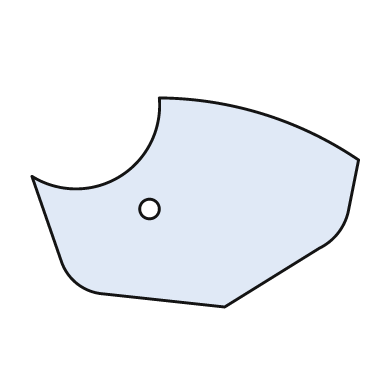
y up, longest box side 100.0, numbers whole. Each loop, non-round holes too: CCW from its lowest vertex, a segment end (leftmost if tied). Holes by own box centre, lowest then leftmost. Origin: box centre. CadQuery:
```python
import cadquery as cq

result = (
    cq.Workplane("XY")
    .moveTo(9.0, -32.0)
    .lineTo(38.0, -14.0)
    .threePointArc((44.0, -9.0), (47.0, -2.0))
    .lineTo(50.0, 13.0)
    .threePointArc((21.0, 27.0), (-11.0, 32.0))
    .threePointArc((-23.0, 8.0), (-50.0, 8.0))
    .lineTo(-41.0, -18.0)
    .threePointArc((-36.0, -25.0), (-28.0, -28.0))
    .close()
    .moveTo(-14.0, -2.0)
    .circle(3.0)
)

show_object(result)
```